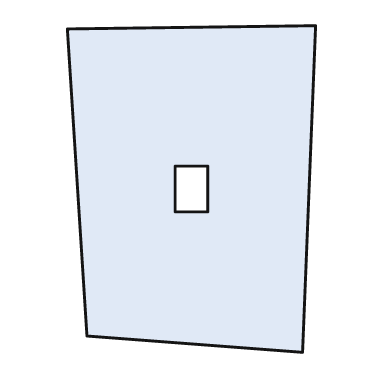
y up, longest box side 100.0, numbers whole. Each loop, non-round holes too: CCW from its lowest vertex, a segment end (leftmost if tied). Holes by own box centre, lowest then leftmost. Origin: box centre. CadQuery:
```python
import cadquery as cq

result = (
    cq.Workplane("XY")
    .moveTo(34.0, -50.0)
    .lineTo(38.0, 50.0)
    .lineTo(-38.0, 49.0)
    .lineTo(-32.0, -45.0)
    .close()
    .moveTo(-5.0, -7.0)
    .lineTo(5.0, -7.0)
    .lineTo(5.0, 7.0)
    .lineTo(-5.0, 7.0)
    .close()
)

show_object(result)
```